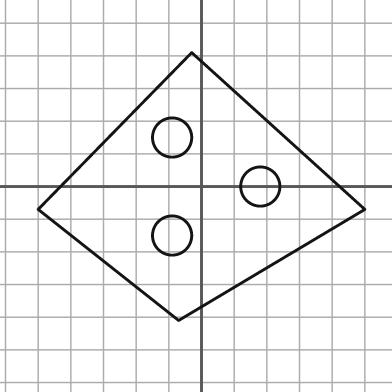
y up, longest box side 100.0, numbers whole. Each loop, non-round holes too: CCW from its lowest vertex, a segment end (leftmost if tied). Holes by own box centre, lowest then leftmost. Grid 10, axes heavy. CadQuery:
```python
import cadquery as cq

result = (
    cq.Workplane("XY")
    .moveTo(-7.0, -41.0)
    .lineTo(50.0, -7.0)
    .lineTo(-3.0, 41.0)
    .lineTo(-50.0, -7.0)
    .close()
    .moveTo(-9.0, -15.0)
    .circle(6.0)
    .moveTo(18.0, 0.0)
    .circle(6.0)
    .moveTo(-9.0, 15.0)
    .circle(6.0)
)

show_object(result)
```